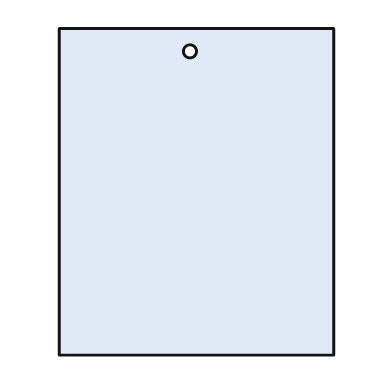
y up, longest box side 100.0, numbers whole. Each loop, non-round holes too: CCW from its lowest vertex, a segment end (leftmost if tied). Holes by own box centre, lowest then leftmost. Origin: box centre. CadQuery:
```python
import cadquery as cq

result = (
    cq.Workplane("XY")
    .moveTo(-42.0, -50.0)
    .lineTo(42.0, -50.0)
    .lineTo(42.0, 50.0)
    .lineTo(-42.0, 50.0)
    .close()
    .moveTo(-2.0, 43.0)
    .circle(2.0)
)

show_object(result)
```